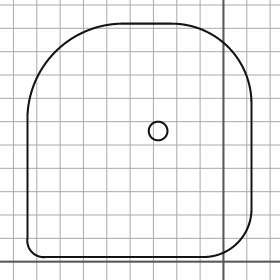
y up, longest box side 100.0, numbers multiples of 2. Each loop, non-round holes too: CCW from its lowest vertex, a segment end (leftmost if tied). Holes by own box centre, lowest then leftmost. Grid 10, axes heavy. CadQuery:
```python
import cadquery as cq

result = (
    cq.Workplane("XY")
    .moveTo(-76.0, 2.0)
    .lineTo(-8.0, 2.0)
    .threePointArc((6.0, 8.0), (12.0, 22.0))
    .lineTo(12.0, 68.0)
    .threePointArc((2.0, 92.0), (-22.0, 102.0))
    .lineTo(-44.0, 102.0)
    .threePointArc((-72.0, 90.0), (-84.0, 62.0))
    .lineTo(-84.0, 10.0)
    .threePointArc((-82.0, 4.0), (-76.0, 2.0))
    .close()
    .moveTo(-28.0, 56.0)
    .circle(4.0)
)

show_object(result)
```